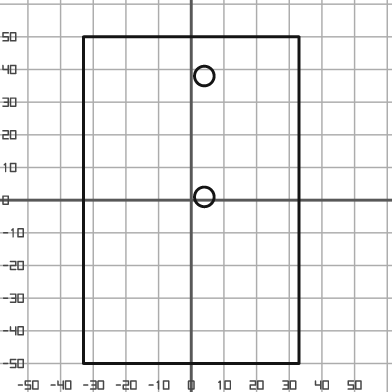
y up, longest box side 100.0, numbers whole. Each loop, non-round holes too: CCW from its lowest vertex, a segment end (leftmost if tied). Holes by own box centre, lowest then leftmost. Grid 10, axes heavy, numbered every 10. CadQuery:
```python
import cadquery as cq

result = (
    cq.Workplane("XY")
    .moveTo(-33.0, -50.0)
    .lineTo(33.0, -50.0)
    .lineTo(33.0, 50.0)
    .lineTo(-33.0, 50.0)
    .close()
    .moveTo(4.0, 1.0)
    .circle(3.0)
    .moveTo(4.0, 38.0)
    .circle(3.0)
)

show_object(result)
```